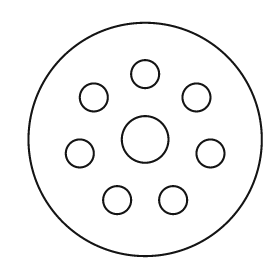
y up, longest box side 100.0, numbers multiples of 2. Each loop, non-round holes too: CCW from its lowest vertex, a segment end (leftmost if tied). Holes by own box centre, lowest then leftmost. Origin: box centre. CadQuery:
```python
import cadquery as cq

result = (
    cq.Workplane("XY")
    .moveTo(0.0, 0.0)
    .circle(50.0)
    .moveTo(-12.0, -26.0)
    .circle(6.0)
    .moveTo(12.0, -26.0)
    .circle(6.0)
    .moveTo(-28.0, -6.0)
    .circle(6.0)
    .moveTo(28.0, -6.0)
    .circle(6.0)
    .moveTo(0.0, 0.0)
    .circle(10.0)
    .moveTo(-22.0, 18.0)
    .circle(6.0)
    .moveTo(22.0, 18.0)
    .circle(6.0)
    .moveTo(0.0, 28.0)
    .circle(6.0)
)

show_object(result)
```